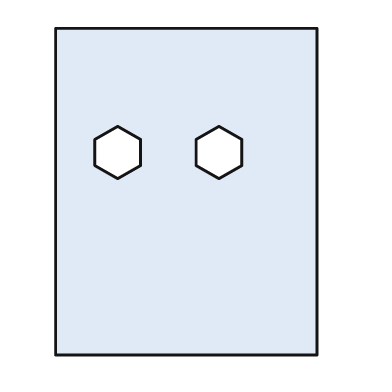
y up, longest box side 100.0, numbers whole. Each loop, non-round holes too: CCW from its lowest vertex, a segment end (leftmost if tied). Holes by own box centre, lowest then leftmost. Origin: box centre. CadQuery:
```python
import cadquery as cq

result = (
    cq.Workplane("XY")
    .moveTo(-40.0, -50.0)
    .lineTo(40.0, -50.0)
    .lineTo(40.0, 50.0)
    .lineTo(-40.0, 50.0)
    .close()
    .moveTo(-21.0, 4.0)
    .lineTo(-14.0, 8.0)
    .lineTo(-14.0, 16.0)
    .lineTo(-21.0, 20.0)
    .lineTo(-28.0, 16.0)
    .lineTo(-28.0, 8.0)
    .close()
    .moveTo(10.0, 4.0)
    .lineTo(17.0, 8.0)
    .lineTo(17.0, 16.0)
    .lineTo(10.0, 20.0)
    .lineTo(3.0, 16.0)
    .lineTo(3.0, 8.0)
    .close()
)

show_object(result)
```